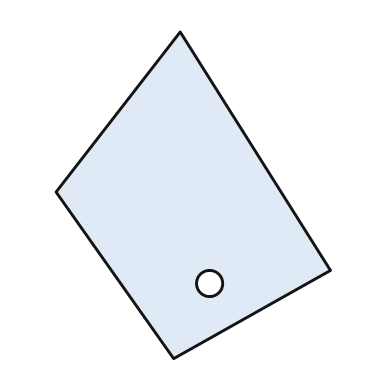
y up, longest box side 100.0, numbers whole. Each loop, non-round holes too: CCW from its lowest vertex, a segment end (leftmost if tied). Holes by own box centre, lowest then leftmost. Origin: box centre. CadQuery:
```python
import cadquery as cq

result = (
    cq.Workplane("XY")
    .moveTo(-6.0, -50.0)
    .lineTo(42.0, -23.0)
    .lineTo(-4.0, 50.0)
    .lineTo(-42.0, 1.0)
    .close()
    .moveTo(5.0, -27.0)
    .circle(4.0)
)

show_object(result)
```